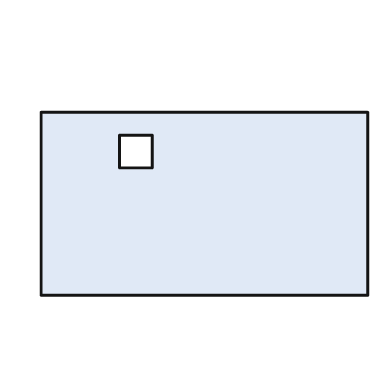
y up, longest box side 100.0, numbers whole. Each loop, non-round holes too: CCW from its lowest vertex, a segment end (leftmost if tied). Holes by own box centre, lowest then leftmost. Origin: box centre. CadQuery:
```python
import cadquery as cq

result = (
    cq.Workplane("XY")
    .moveTo(-50.0, -28.0)
    .lineTo(50.0, -28.0)
    .lineTo(50.0, 28.0)
    .lineTo(-50.0, 28.0)
    .close()
    .moveTo(-26.0, 11.0)
    .lineTo(-16.0, 11.0)
    .lineTo(-16.0, 21.0)
    .lineTo(-26.0, 21.0)
    .close()
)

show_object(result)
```